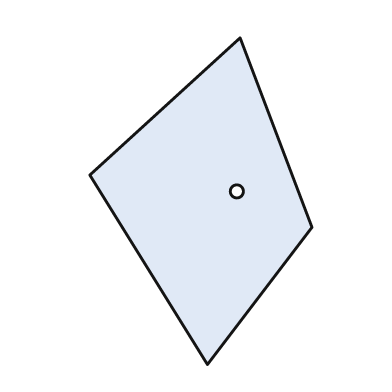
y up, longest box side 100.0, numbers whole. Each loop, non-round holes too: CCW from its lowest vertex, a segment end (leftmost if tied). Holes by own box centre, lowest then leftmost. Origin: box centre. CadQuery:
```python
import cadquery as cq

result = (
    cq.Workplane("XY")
    .moveTo(2.0, -50.0)
    .lineTo(34.0, -8.0)
    .lineTo(12.0, 50.0)
    .lineTo(-34.0, 8.0)
    .close()
    .moveTo(11.0, 3.0)
    .circle(2.0)
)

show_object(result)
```